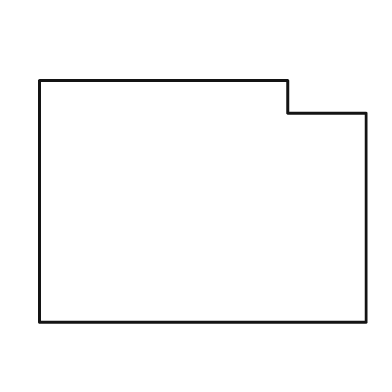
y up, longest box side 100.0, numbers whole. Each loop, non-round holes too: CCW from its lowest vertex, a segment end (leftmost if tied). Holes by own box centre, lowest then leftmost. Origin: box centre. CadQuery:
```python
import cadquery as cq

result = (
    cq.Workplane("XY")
    .moveTo(-50.0, -37.0)
    .lineTo(50.0, -37.0)
    .lineTo(50.0, 27.0)
    .lineTo(26.0, 27.0)
    .lineTo(26.0, 37.0)
    .lineTo(-50.0, 37.0)
    .close()
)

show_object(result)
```